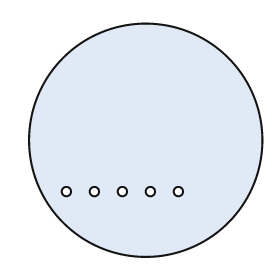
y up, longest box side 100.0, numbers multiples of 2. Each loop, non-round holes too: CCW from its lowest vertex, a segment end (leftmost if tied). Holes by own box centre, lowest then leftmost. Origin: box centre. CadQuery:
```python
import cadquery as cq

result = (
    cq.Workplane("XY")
    .moveTo(0.0, 0.0)
    .circle(50.0)
    .moveTo(-34.0, -22.0)
    .circle(2.0)
    .moveTo(-22.0, -22.0)
    .circle(2.0)
    .moveTo(-10.0, -22.0)
    .circle(2.0)
    .moveTo(2.0, -22.0)
    .circle(2.0)
    .moveTo(14.0, -22.0)
    .circle(2.0)
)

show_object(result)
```